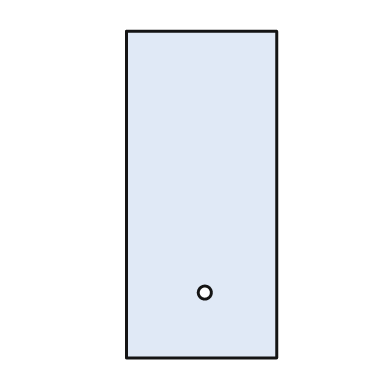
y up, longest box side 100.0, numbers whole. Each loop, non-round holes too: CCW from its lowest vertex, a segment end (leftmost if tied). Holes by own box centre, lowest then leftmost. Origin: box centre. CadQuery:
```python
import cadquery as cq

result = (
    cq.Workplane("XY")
    .moveTo(-23.0, -50.0)
    .lineTo(23.0, -50.0)
    .lineTo(23.0, 50.0)
    .lineTo(-23.0, 50.0)
    .close()
    .moveTo(1.0, -30.0)
    .circle(2.0)
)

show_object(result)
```